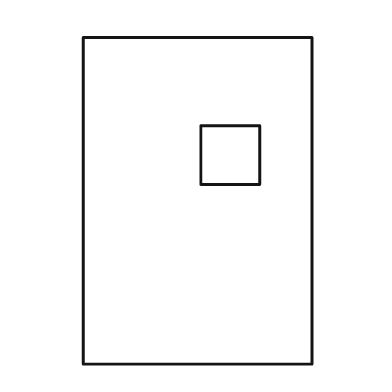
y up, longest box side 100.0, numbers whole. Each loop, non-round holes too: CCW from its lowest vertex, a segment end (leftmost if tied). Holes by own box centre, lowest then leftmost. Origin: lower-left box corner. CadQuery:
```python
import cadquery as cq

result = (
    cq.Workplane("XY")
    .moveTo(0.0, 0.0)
    .lineTo(70.0, 0.0)
    .lineTo(70.0, 100.0)
    .lineTo(0.0, 100.0)
    .close()
    .moveTo(36.0, 55.0)
    .lineTo(54.0, 55.0)
    .lineTo(54.0, 73.0)
    .lineTo(36.0, 73.0)
    .close()
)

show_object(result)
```